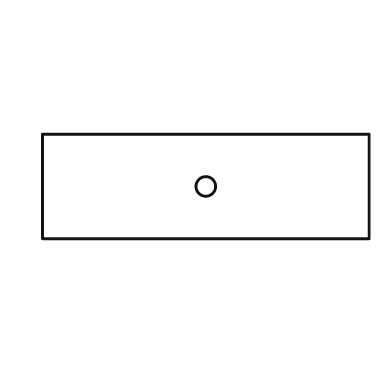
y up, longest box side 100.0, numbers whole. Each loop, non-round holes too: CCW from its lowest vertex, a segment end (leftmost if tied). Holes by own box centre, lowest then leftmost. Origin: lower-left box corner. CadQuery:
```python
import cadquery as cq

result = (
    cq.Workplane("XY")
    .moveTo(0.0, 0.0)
    .lineTo(100.0, 0.0)
    .lineTo(100.0, 32.0)
    .lineTo(0.0, 32.0)
    .close()
    .moveTo(50.0, 16.0)
    .circle(3.0)
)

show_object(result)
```